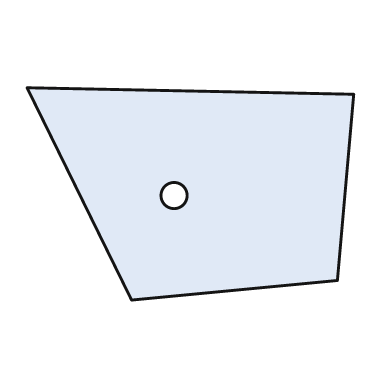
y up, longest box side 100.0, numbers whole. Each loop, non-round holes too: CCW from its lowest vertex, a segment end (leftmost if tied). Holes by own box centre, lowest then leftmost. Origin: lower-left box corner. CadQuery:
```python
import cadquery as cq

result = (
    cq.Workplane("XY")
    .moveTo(32.0, 0.0)
    .lineTo(95.0, 6.0)
    .lineTo(100.0, 63.0)
    .lineTo(0.0, 65.0)
    .close()
    .moveTo(45.0, 32.0)
    .circle(4.0)
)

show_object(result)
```